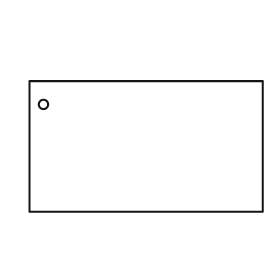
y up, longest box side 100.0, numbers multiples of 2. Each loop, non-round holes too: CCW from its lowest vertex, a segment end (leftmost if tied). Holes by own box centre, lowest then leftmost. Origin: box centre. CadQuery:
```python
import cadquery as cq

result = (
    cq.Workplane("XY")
    .moveTo(-50.0, -28.0)
    .lineTo(50.0, -28.0)
    .lineTo(50.0, 28.0)
    .lineTo(-50.0, 28.0)
    .close()
    .moveTo(-44.0, 18.0)
    .circle(2.0)
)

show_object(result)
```